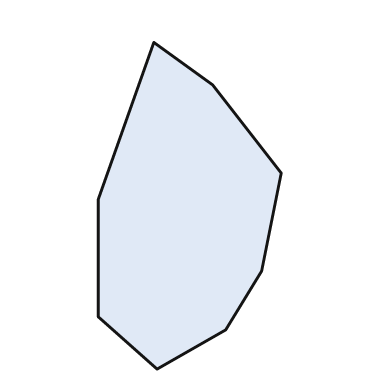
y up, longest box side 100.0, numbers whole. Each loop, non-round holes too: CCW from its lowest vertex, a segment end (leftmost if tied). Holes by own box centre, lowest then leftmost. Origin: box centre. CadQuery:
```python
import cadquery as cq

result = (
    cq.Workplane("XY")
    .moveTo(-10.0, -50.0)
    .lineTo(11.0, -38.0)
    .lineTo(22.0, -20.0)
    .lineTo(28.0, 10.0)
    .lineTo(7.0, 37.0)
    .lineTo(-11.0, 50.0)
    .lineTo(-28.0, 2.0)
    .lineTo(-28.0, -34.0)
    .close()
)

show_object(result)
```